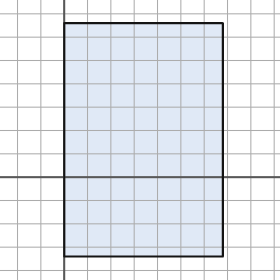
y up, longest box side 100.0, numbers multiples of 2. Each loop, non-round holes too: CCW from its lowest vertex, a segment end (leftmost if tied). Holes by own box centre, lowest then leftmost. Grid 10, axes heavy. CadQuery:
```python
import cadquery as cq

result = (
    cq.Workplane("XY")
    .moveTo(0.0, -34.0)
    .lineTo(68.0, -34.0)
    .lineTo(68.0, 66.0)
    .lineTo(0.0, 66.0)
    .close()
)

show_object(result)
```